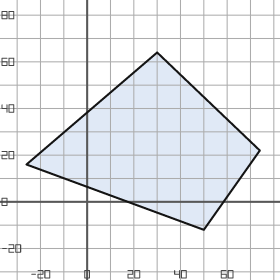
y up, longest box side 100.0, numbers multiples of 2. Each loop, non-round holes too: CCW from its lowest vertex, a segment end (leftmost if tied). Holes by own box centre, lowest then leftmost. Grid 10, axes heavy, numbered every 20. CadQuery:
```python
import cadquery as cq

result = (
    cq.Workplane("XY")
    .moveTo(50.0, -12.0)
    .lineTo(74.0, 22.0)
    .lineTo(30.0, 64.0)
    .lineTo(-26.0, 16.0)
    .close()
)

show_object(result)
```